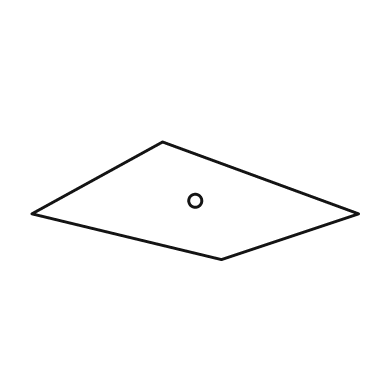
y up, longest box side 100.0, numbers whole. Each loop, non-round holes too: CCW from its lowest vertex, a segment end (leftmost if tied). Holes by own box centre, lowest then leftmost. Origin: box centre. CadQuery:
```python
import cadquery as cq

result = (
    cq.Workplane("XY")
    .moveTo(8.0, -18.0)
    .lineTo(50.0, -4.0)
    .lineTo(-10.0, 18.0)
    .lineTo(-50.0, -4.0)
    .close()
    .moveTo(0.0, 0.0)
    .circle(2.0)
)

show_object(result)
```